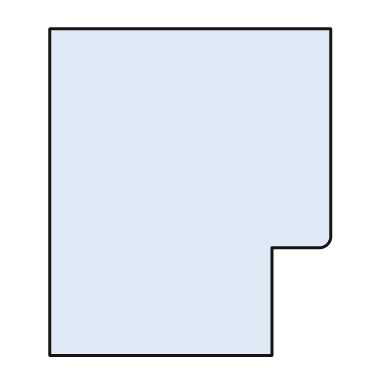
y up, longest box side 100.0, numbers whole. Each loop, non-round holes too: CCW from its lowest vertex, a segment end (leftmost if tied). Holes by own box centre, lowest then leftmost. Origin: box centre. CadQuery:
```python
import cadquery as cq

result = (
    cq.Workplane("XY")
    .moveTo(-43.0, -50.0)
    .lineTo(25.0, -50.0)
    .lineTo(25.0, -17.0)
    .lineTo(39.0, -17.0)
    .threePointArc((42.0, -16.0), (43.0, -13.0))
    .lineTo(43.0, 50.0)
    .lineTo(-43.0, 50.0)
    .close()
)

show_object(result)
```